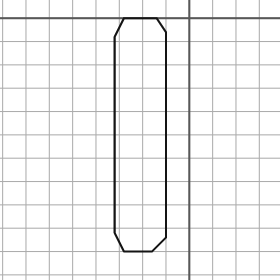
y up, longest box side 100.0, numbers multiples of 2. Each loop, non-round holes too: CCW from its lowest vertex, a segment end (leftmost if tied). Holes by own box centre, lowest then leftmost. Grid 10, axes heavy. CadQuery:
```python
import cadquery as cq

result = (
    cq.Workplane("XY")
    .moveTo(-28.0, -100.0)
    .lineTo(-16.0, -100.0)
    .lineTo(-10.0, -94.0)
    .lineTo(-10.0, -6.0)
    .lineTo(-14.0, 0.0)
    .lineTo(-28.0, 0.0)
    .lineTo(-32.0, -8.0)
    .lineTo(-32.0, -92.0)
    .close()
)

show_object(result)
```